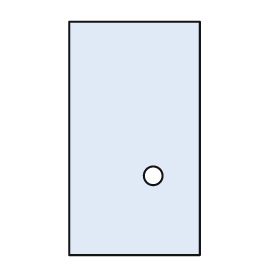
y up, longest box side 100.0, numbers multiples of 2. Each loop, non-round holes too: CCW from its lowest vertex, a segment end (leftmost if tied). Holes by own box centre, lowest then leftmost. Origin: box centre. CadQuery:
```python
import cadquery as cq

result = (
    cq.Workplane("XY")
    .moveTo(-28.0, -50.0)
    .lineTo(28.0, -50.0)
    .lineTo(28.0, 50.0)
    .lineTo(-28.0, 50.0)
    .close()
    .moveTo(8.0, -16.0)
    .circle(4.0)
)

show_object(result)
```